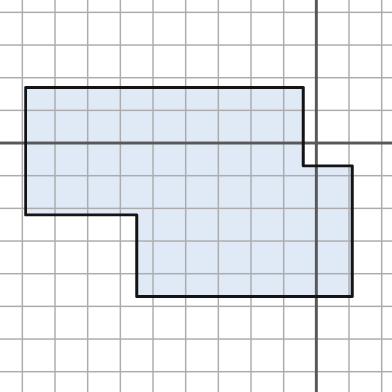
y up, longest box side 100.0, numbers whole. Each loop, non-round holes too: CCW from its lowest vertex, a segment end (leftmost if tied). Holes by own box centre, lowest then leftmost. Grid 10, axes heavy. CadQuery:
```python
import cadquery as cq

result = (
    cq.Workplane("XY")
    .moveTo(-55.0, -47.0)
    .lineTo(11.0, -47.0)
    .lineTo(11.0, -7.0)
    .lineTo(-4.0, -7.0)
    .lineTo(-4.0, 17.0)
    .lineTo(-89.0, 17.0)
    .lineTo(-89.0, -22.0)
    .lineTo(-55.0, -22.0)
    .close()
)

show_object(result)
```